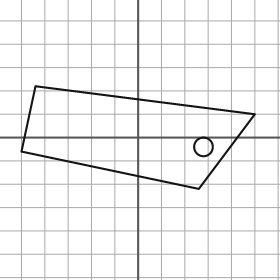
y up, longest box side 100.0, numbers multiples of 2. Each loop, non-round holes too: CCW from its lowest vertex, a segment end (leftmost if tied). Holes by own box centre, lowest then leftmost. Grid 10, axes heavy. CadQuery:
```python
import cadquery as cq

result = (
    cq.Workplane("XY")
    .moveTo(26.0, -22.0)
    .lineTo(50.0, 10.0)
    .lineTo(-44.0, 22.0)
    .lineTo(-50.0, -6.0)
    .close()
    .moveTo(28.0, -4.0)
    .circle(4.0)
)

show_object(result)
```